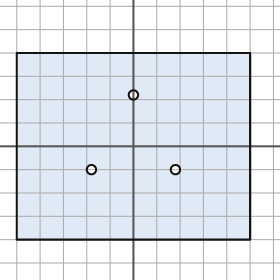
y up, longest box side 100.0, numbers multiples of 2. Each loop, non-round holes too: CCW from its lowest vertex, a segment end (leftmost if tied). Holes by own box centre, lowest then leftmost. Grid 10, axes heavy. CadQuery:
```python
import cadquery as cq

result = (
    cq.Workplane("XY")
    .moveTo(-50.0, -40.0)
    .lineTo(50.0, -40.0)
    .lineTo(50.0, 40.0)
    .lineTo(-50.0, 40.0)
    .close()
    .moveTo(-18.0, -10.0)
    .circle(2.0)
    .moveTo(18.0, -10.0)
    .circle(2.0)
    .moveTo(0.0, 22.0)
    .circle(2.0)
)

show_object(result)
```